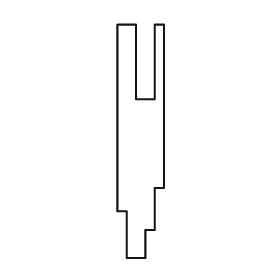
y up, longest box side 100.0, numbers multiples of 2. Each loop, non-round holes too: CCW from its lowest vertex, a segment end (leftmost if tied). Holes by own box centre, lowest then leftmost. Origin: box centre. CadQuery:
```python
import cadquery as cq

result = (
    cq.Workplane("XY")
    .moveTo(-6.0, -50.0)
    .lineTo(2.0, -50.0)
    .lineTo(2.0, -38.0)
    .lineTo(6.0, -38.0)
    .lineTo(6.0, -20.0)
    .lineTo(10.0, -20.0)
    .lineTo(10.0, 50.0)
    .lineTo(6.0, 50.0)
    .lineTo(6.0, 18.0)
    .lineTo(-2.0, 18.0)
    .lineTo(-2.0, 50.0)
    .lineTo(-10.0, 50.0)
    .lineTo(-10.0, -30.0)
    .lineTo(-6.0, -30.0)
    .close()
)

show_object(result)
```